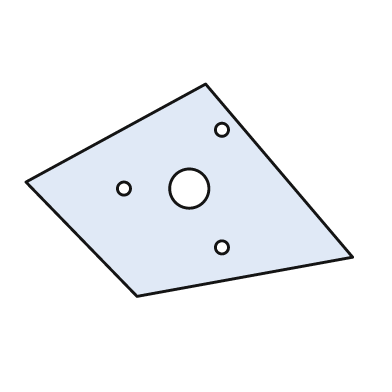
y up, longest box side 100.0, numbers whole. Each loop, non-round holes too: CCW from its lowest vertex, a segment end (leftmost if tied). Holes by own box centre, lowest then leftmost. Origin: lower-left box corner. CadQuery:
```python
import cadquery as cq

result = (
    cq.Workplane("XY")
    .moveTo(34.0, 0.0)
    .lineTo(100.0, 12.0)
    .lineTo(55.0, 65.0)
    .lineTo(0.0, 35.0)
    .close()
    .moveTo(60.0, 15.0)
    .circle(2.0)
    .moveTo(30.0, 33.0)
    .circle(2.0)
    .moveTo(50.0, 33.0)
    .circle(6.0)
    .moveTo(60.0, 51.0)
    .circle(2.0)
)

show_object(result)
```